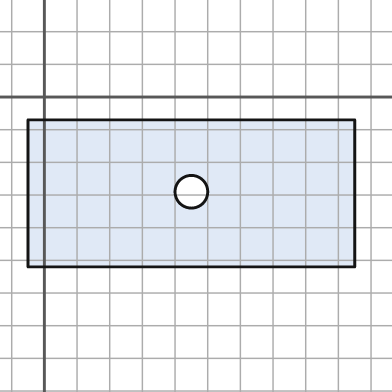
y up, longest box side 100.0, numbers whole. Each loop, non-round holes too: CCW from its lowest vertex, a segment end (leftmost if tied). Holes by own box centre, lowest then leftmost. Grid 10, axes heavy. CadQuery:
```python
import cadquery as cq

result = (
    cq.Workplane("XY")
    .moveTo(-5.0, -52.0)
    .lineTo(95.0, -52.0)
    .lineTo(95.0, -7.0)
    .lineTo(-5.0, -7.0)
    .close()
    .moveTo(45.0, -29.0)
    .circle(5.0)
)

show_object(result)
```